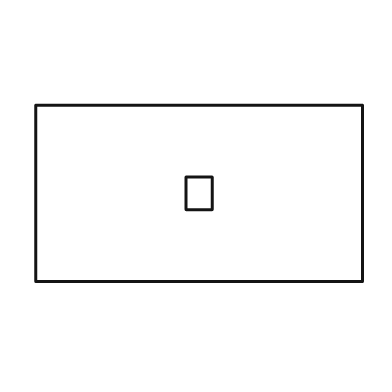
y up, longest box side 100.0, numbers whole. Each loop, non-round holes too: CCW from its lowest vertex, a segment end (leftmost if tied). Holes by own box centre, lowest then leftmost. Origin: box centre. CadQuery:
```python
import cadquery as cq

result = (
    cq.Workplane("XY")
    .moveTo(-50.0, -27.0)
    .lineTo(50.0, -27.0)
    .lineTo(50.0, 27.0)
    .lineTo(-50.0, 27.0)
    .close()
    .moveTo(-4.0, -5.0)
    .lineTo(4.0, -5.0)
    .lineTo(4.0, 5.0)
    .lineTo(-4.0, 5.0)
    .close()
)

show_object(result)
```